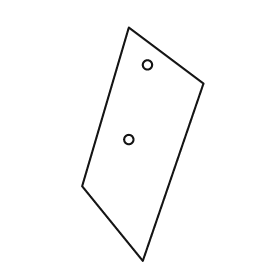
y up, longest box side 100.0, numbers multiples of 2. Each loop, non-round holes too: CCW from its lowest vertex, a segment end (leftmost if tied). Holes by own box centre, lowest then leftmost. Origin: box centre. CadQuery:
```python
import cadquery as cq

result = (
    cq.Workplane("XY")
    .moveTo(0.0, -50.0)
    .lineTo(26.0, 26.0)
    .lineTo(-6.0, 50.0)
    .lineTo(-26.0, -18.0)
    .close()
    .moveTo(-6.0, 2.0)
    .circle(2.0)
    .moveTo(2.0, 34.0)
    .circle(2.0)
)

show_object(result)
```